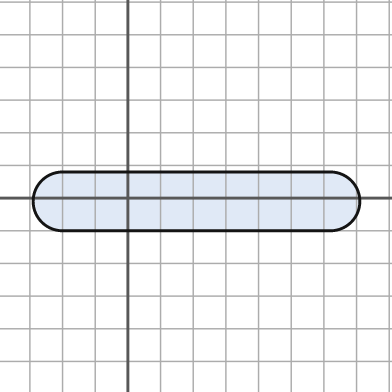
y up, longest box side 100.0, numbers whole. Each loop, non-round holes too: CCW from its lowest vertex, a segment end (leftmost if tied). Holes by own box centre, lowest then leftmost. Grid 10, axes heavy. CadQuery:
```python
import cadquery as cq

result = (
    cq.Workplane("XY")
    .moveTo(-20.0, -10.0)
    .lineTo(62.0, -10.0)
    .threePointArc((71.0, -1.0), (62.0, 8.0))
    .lineTo(-20.0, 8.0)
    .threePointArc((-29.0, -1.0), (-20.0, -10.0))
    .close()
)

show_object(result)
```